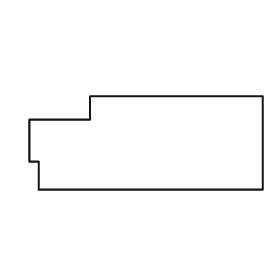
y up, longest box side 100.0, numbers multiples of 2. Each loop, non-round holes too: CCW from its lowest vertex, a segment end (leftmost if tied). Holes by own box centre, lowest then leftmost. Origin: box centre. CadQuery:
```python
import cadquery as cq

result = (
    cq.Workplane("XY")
    .moveTo(-46.0, -20.0)
    .lineTo(50.0, -20.0)
    .lineTo(50.0, 20.0)
    .lineTo(-24.0, 20.0)
    .lineTo(-24.0, 10.0)
    .lineTo(-50.0, 10.0)
    .lineTo(-50.0, -8.0)
    .lineTo(-46.0, -8.0)
    .close()
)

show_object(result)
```